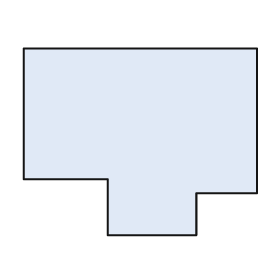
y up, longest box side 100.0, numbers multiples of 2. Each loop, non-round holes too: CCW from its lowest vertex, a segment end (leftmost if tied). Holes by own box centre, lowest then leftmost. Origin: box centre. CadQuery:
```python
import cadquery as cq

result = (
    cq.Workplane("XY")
    .moveTo(-14.0, -40.0)
    .lineTo(24.0, -40.0)
    .lineTo(24.0, -22.0)
    .lineTo(50.0, -22.0)
    .lineTo(50.0, 40.0)
    .lineTo(-50.0, 40.0)
    .lineTo(-50.0, -16.0)
    .lineTo(-14.0, -16.0)
    .close()
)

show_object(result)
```